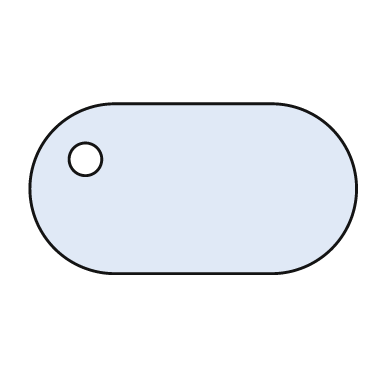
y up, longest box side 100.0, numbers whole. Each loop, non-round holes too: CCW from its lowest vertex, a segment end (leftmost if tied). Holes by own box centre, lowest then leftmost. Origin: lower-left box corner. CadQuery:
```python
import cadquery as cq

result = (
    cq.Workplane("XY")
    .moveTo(26.0, 0.0)
    .lineTo(74.0, 0.0)
    .threePointArc((100.0, 26.0), (74.0, 52.0))
    .lineTo(26.0, 52.0)
    .threePointArc((0.0, 26.0), (26.0, 0.0))
    .close()
    .moveTo(17.0, 35.0)
    .circle(5.0)
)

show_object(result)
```